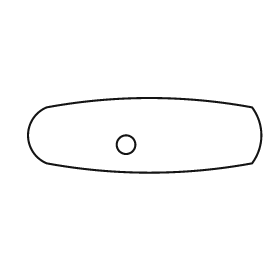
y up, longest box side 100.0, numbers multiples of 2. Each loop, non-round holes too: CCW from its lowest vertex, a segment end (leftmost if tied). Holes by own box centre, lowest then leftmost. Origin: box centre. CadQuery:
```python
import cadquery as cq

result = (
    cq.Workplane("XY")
    .moveTo(-42.0, -12.0)
    .threePointArc((2.0, -16.0), (46.0, -12.0))
    .threePointArc((50.0, 0.0), (46.0, 12.0))
    .threePointArc((2.0, 16.0), (-42.0, 12.0))
    .threePointArc((-50.0, 0.0), (-42.0, -12.0))
    .close()
    .moveTo(-8.0, -4.0)
    .circle(4.0)
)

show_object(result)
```